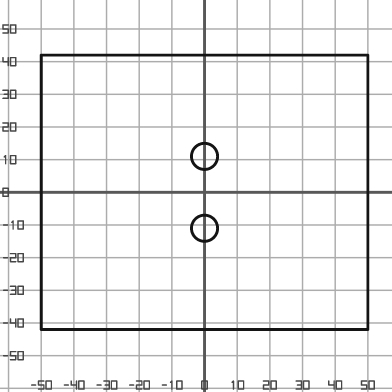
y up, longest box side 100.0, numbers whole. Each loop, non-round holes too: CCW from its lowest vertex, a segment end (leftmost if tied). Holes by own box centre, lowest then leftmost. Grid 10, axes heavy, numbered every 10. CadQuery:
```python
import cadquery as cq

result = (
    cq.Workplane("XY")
    .moveTo(-50.0, -42.0)
    .lineTo(50.0, -42.0)
    .lineTo(50.0, 42.0)
    .lineTo(-50.0, 42.0)
    .close()
    .moveTo(0.0, -11.0)
    .circle(4.0)
    .moveTo(0.0, 11.0)
    .circle(4.0)
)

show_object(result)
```